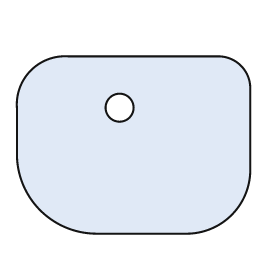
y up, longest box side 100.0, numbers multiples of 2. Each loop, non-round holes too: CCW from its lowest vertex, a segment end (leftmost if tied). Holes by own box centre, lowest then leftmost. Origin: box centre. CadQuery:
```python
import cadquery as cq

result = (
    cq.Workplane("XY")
    .moveTo(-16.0, -38.0)
    .lineTo(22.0, -38.0)
    .threePointArc((42.0, -30.0), (50.0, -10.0))
    .lineTo(50.0, 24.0)
    .threePointArc((46.0, 34.0), (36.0, 38.0))
    .lineTo(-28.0, 38.0)
    .threePointArc((-44.0, 32.0), (-50.0, 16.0))
    .lineTo(-50.0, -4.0)
    .threePointArc((-40.0, -28.0), (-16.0, -38.0))
    .close()
    .moveTo(-6.0, 16.0)
    .circle(6.0)
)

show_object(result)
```